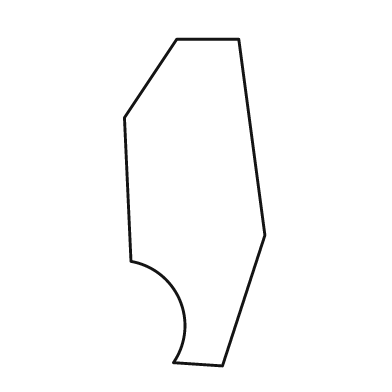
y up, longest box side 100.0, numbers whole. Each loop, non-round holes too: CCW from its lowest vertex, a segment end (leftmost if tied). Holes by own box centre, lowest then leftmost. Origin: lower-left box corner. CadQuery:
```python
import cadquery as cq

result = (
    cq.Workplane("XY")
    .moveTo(30.0, 0.0)
    .lineTo(43.0, 40.0)
    .lineTo(35.0, 100.0)
    .lineTo(16.0, 100.0)
    .lineTo(0.0, 76.0)
    .lineTo(2.0, 32.0)
    .threePointArc((17.0, 20.0), (15.0, 1.0))
    .close()
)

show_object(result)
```